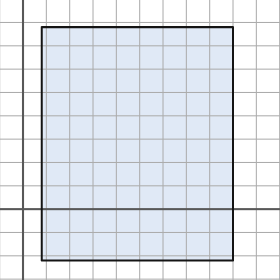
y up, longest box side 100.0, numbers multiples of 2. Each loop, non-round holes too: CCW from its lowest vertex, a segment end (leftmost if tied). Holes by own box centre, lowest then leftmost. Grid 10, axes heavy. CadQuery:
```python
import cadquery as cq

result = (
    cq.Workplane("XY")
    .moveTo(8.0, -22.0)
    .lineTo(90.0, -22.0)
    .lineTo(90.0, 78.0)
    .lineTo(8.0, 78.0)
    .close()
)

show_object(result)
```